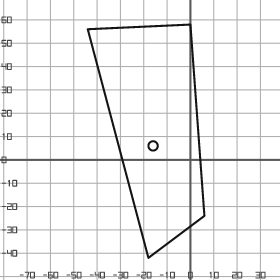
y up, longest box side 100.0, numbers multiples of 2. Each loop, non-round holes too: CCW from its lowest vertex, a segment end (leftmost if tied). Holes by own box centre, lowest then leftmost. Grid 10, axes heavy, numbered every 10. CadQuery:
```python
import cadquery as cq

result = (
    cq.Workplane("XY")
    .moveTo(-18.0, -42.0)
    .lineTo(6.0, -24.0)
    .lineTo(0.0, 58.0)
    .lineTo(-44.0, 56.0)
    .close()
    .moveTo(-16.0, 6.0)
    .circle(2.0)
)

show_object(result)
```